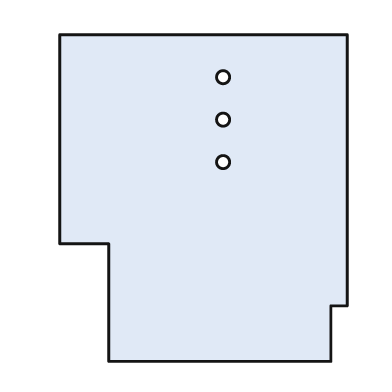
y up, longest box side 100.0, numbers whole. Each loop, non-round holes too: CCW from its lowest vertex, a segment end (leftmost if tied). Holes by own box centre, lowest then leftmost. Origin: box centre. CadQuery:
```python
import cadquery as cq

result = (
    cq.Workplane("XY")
    .moveTo(-29.0, -50.0)
    .lineTo(39.0, -50.0)
    .lineTo(39.0, -33.0)
    .lineTo(44.0, -33.0)
    .lineTo(44.0, 50.0)
    .lineTo(-44.0, 50.0)
    .lineTo(-44.0, -14.0)
    .lineTo(-29.0, -14.0)
    .close()
    .moveTo(6.0, 11.0)
    .circle(2.0)
    .moveTo(6.0, 24.0)
    .circle(2.0)
    .moveTo(6.0, 37.0)
    .circle(2.0)
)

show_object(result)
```